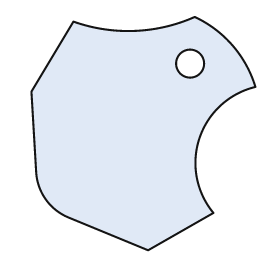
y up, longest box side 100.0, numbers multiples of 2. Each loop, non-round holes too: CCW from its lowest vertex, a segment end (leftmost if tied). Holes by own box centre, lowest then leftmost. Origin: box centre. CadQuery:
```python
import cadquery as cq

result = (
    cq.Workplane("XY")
    .moveTo(2.0, -50.0)
    .lineTo(30.0, -34.0)
    .threePointArc((24.0, -2.0), (48.0, 20.0))
    .threePointArc((38.0, 38.0), (22.0, 50.0))
    .threePointArc((-4.0, 44.0), (-30.0, 48.0))
    .lineTo(-48.0, 18.0)
    .lineTo(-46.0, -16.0)
    .threePointArc((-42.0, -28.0), (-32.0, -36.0))
    .close()
    .moveTo(20.0, 30.0)
    .circle(6.0)
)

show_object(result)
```